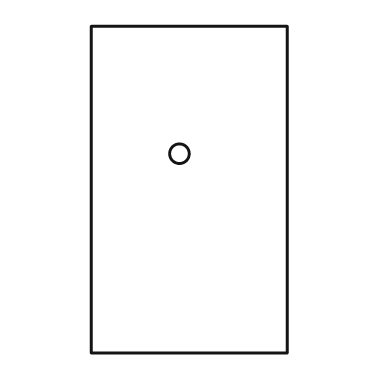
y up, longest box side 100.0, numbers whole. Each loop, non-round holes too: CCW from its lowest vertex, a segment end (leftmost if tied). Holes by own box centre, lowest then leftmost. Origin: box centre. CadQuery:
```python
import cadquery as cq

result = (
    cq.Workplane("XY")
    .moveTo(-30.0, -50.0)
    .lineTo(30.0, -50.0)
    .lineTo(30.0, 50.0)
    .lineTo(-30.0, 50.0)
    .close()
    .moveTo(-3.0, 11.0)
    .circle(3.0)
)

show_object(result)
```